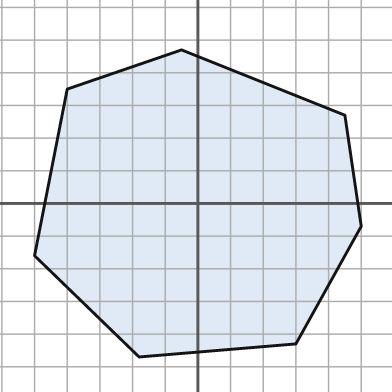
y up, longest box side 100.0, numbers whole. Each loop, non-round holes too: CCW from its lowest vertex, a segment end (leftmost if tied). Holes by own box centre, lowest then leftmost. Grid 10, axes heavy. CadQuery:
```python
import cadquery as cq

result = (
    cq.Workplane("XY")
    .moveTo(-18.0, -47.0)
    .lineTo(30.0, -43.0)
    .lineTo(50.0, -7.0)
    .lineTo(45.0, 27.0)
    .lineTo(-5.0, 47.0)
    .lineTo(-40.0, 35.0)
    .lineTo(-50.0, -16.0)
    .close()
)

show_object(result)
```